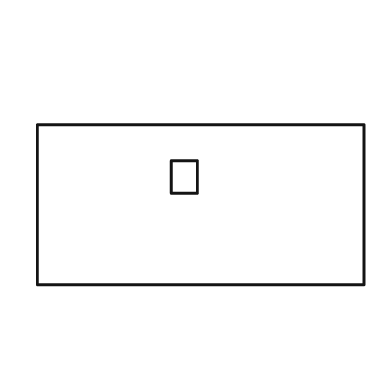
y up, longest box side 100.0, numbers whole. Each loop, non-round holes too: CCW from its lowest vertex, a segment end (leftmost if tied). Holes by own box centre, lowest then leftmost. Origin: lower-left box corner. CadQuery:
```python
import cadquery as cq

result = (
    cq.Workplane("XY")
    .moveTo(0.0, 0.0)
    .lineTo(100.0, 0.0)
    .lineTo(100.0, 49.0)
    .lineTo(0.0, 49.0)
    .close()
    .moveTo(41.0, 28.0)
    .lineTo(49.0, 28.0)
    .lineTo(49.0, 38.0)
    .lineTo(41.0, 38.0)
    .close()
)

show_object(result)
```